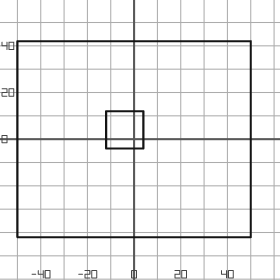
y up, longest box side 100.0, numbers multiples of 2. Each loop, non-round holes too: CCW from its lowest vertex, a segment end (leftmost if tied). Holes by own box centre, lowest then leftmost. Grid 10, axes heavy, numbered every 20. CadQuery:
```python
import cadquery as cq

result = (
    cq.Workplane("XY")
    .moveTo(-50.0, -42.0)
    .lineTo(50.0, -42.0)
    .lineTo(50.0, 42.0)
    .lineTo(-50.0, 42.0)
    .close()
    .moveTo(-12.0, -4.0)
    .lineTo(4.0, -4.0)
    .lineTo(4.0, 12.0)
    .lineTo(-12.0, 12.0)
    .close()
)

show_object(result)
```